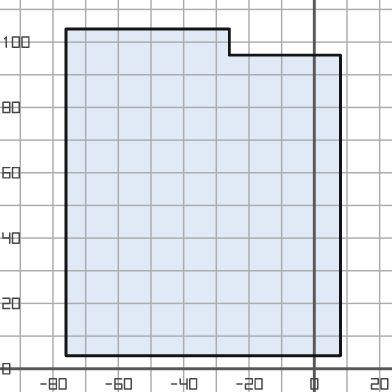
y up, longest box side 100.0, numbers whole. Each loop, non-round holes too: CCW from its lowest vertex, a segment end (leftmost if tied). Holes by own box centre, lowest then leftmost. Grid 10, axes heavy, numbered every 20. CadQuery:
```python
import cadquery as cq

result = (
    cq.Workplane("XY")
    .moveTo(-76.0, 4.0)
    .lineTo(8.0, 4.0)
    .lineTo(8.0, 96.0)
    .lineTo(-26.0, 96.0)
    .lineTo(-26.0, 104.0)
    .lineTo(-76.0, 104.0)
    .close()
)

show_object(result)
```